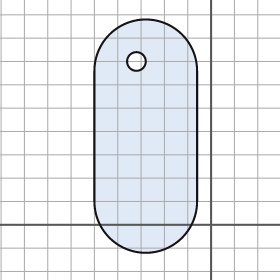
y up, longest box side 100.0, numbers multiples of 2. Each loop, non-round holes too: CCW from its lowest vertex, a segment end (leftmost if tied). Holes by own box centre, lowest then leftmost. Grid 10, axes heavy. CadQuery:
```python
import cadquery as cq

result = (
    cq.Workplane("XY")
    .moveTo(-50.0, 10.0)
    .threePointArc((-28.0, -12.0), (-6.0, 10.0))
    .lineTo(-6.0, 66.0)
    .threePointArc((-28.0, 88.0), (-50.0, 66.0))
    .close()
    .moveTo(-32.0, 70.0)
    .circle(4.0)
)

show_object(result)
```